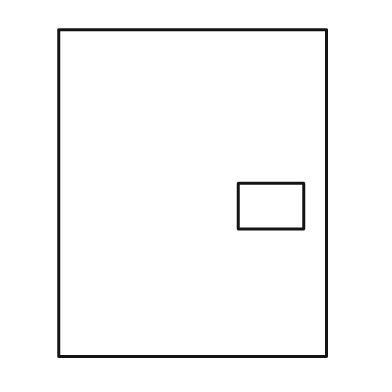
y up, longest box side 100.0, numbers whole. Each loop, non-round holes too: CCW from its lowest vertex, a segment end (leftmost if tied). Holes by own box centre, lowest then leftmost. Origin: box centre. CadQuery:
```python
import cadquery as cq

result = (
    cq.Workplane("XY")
    .moveTo(-41.0, -50.0)
    .lineTo(41.0, -50.0)
    .lineTo(41.0, 50.0)
    .lineTo(-41.0, 50.0)
    .close()
    .moveTo(14.0, -11.0)
    .lineTo(34.0, -11.0)
    .lineTo(34.0, 3.0)
    .lineTo(14.0, 3.0)
    .close()
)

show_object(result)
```